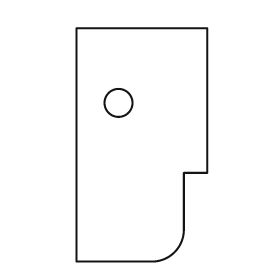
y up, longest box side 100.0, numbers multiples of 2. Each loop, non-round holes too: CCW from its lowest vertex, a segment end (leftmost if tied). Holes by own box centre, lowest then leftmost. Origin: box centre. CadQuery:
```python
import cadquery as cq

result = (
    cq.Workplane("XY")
    .moveTo(-28.0, -50.0)
    .lineTo(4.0, -50.0)
    .threePointArc((14.0, -46.0), (18.0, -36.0))
    .lineTo(18.0, -12.0)
    .lineTo(28.0, -12.0)
    .lineTo(28.0, 50.0)
    .lineTo(-28.0, 50.0)
    .close()
    .moveTo(-10.0, 18.0)
    .circle(6.0)
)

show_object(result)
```